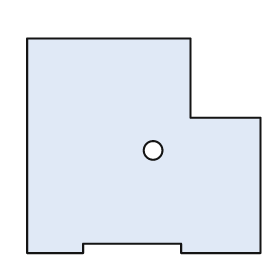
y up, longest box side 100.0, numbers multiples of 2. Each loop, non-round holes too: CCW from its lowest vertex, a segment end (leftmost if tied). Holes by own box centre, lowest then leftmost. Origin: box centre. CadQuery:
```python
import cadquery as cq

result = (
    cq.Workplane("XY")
    .moveTo(-50.0, -46.0)
    .lineTo(-26.0, -46.0)
    .lineTo(-26.0, -42.0)
    .lineTo(16.0, -42.0)
    .lineTo(16.0, -46.0)
    .lineTo(50.0, -46.0)
    .lineTo(50.0, 12.0)
    .lineTo(20.0, 12.0)
    .lineTo(20.0, 46.0)
    .lineTo(-50.0, 46.0)
    .close()
    .moveTo(4.0, -2.0)
    .circle(4.0)
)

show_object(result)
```